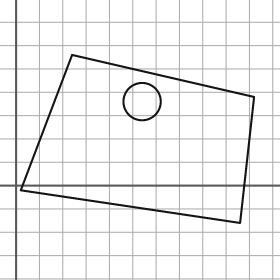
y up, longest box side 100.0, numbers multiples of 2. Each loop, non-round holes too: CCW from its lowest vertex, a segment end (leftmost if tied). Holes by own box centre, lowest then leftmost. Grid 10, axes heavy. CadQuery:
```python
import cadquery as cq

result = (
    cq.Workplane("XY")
    .moveTo(96.0, -16.0)
    .lineTo(102.0, 38.0)
    .lineTo(24.0, 56.0)
    .lineTo(2.0, -2.0)
    .close()
    .moveTo(54.0, 36.0)
    .circle(8.0)
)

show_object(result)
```